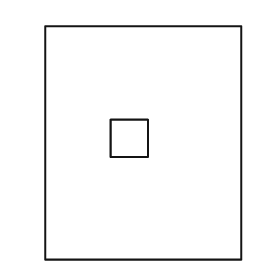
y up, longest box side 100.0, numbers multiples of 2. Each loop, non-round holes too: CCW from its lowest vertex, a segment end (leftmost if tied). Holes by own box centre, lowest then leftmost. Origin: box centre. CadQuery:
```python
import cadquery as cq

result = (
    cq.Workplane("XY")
    .moveTo(-42.0, -50.0)
    .lineTo(42.0, -50.0)
    .lineTo(42.0, 50.0)
    .lineTo(-42.0, 50.0)
    .close()
    .moveTo(-14.0, -6.0)
    .lineTo(2.0, -6.0)
    .lineTo(2.0, 10.0)
    .lineTo(-14.0, 10.0)
    .close()
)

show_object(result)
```